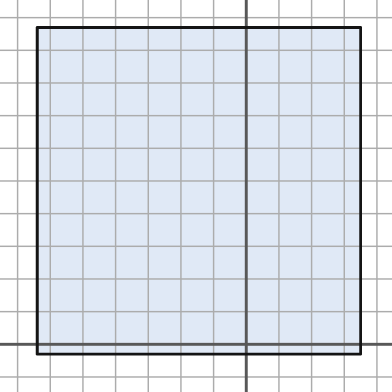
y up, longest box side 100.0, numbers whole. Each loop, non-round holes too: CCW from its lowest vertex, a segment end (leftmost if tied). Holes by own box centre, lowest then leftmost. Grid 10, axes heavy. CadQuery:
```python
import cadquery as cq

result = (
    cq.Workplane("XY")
    .moveTo(-64.0, -3.0)
    .lineTo(35.0, -3.0)
    .lineTo(35.0, 97.0)
    .lineTo(-64.0, 97.0)
    .close()
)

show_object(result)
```